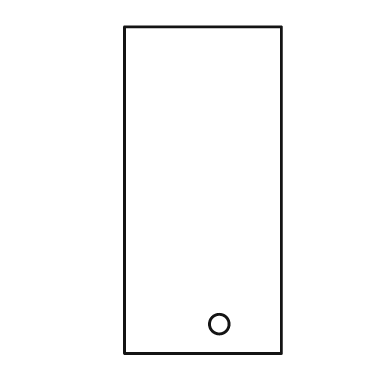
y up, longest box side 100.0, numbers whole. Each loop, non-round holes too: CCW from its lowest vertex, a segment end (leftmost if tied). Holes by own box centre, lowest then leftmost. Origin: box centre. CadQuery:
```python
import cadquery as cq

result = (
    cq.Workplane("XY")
    .moveTo(-24.0, -50.0)
    .lineTo(24.0, -50.0)
    .lineTo(24.0, 50.0)
    .lineTo(-24.0, 50.0)
    .close()
    .moveTo(5.0, -41.0)
    .circle(3.0)
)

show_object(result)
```